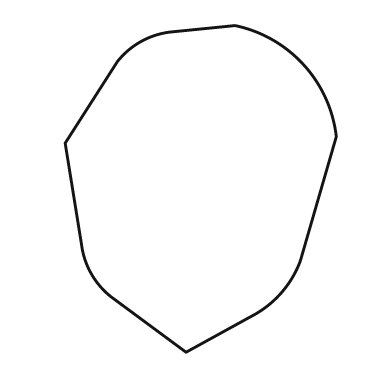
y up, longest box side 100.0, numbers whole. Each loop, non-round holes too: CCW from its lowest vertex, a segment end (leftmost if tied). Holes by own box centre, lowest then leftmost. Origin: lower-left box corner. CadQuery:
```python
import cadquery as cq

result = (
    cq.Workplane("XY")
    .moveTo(37.0, 0.0)
    .lineTo(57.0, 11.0)
    .threePointArc((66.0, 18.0), (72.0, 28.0))
    .lineTo(83.0, 66.0)
    .threePointArc((73.0, 88.0), (52.0, 100.0))
    .lineTo(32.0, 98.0)
    .threePointArc((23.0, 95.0), (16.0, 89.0))
    .lineTo(0.0, 64.0)
    .lineTo(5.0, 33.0)
    .threePointArc((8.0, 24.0), (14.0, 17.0))
    .close()
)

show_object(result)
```